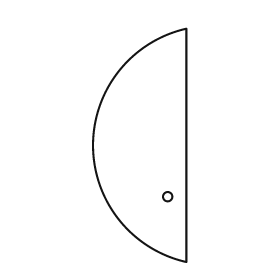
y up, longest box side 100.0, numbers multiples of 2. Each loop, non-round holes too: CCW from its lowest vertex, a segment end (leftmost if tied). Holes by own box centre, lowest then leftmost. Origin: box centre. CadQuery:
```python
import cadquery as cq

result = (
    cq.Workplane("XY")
    .moveTo(20.0, -50.0)
    .lineTo(20.0, 50.0)
    .threePointArc((-20.0, 0.0), (20.0, -50.0))
    .close()
    .moveTo(12.0, -22.0)
    .circle(2.0)
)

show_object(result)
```